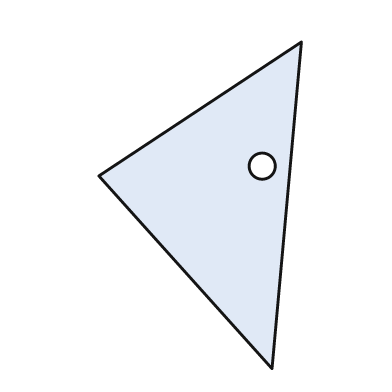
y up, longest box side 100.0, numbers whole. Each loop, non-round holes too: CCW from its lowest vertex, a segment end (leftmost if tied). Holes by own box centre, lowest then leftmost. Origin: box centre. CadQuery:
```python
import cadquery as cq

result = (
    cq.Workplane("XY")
    .moveTo(22.0, -50.0)
    .lineTo(31.0, 50.0)
    .lineTo(-31.0, 9.0)
    .close()
    .moveTo(19.0, 12.0)
    .circle(4.0)
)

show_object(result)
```